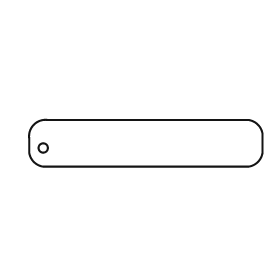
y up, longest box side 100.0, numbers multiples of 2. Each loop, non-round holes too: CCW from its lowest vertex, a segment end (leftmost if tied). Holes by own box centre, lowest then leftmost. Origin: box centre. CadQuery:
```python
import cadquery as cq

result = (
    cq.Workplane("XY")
    .moveTo(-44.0, -10.0)
    .lineTo(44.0, -10.0)
    .threePointArc((48.0, -8.0), (50.0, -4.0))
    .lineTo(50.0, 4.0)
    .threePointArc((48.0, 8.0), (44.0, 10.0))
    .lineTo(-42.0, 10.0)
    .threePointArc((-48.0, 8.0), (-50.0, 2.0))
    .lineTo(-50.0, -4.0)
    .threePointArc((-48.0, -8.0), (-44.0, -10.0))
    .close()
    .moveTo(-44.0, -2.0)
    .circle(2.0)
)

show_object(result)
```